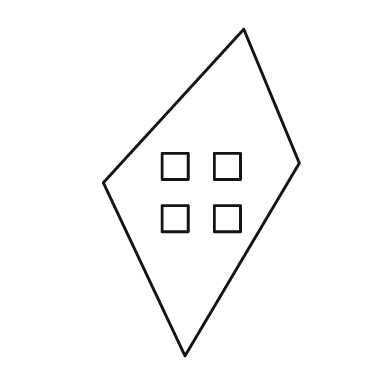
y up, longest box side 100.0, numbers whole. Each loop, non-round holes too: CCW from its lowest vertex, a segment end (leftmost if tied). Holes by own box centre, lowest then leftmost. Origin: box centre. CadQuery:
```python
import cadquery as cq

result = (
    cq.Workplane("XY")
    .moveTo(-5.0, -50.0)
    .lineTo(30.0, 9.0)
    .lineTo(13.0, 50.0)
    .lineTo(-30.0, 3.0)
    .close()
    .moveTo(-12.0, -12.0)
    .lineTo(-4.0, -12.0)
    .lineTo(-4.0, -4.0)
    .lineTo(-12.0, -4.0)
    .close()
    .moveTo(4.0, -12.0)
    .lineTo(12.0, -12.0)
    .lineTo(12.0, -4.0)
    .lineTo(4.0, -4.0)
    .close()
    .moveTo(-12.0, 4.0)
    .lineTo(-4.0, 4.0)
    .lineTo(-4.0, 12.0)
    .lineTo(-12.0, 12.0)
    .close()
    .moveTo(4.0, 4.0)
    .lineTo(12.0, 4.0)
    .lineTo(12.0, 12.0)
    .lineTo(4.0, 12.0)
    .close()
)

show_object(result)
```